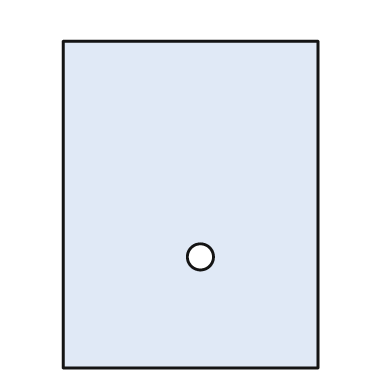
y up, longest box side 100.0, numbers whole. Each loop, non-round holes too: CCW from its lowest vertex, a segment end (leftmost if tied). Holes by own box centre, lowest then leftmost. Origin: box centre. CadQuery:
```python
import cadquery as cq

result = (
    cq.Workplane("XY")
    .moveTo(-39.0, -50.0)
    .lineTo(39.0, -50.0)
    .lineTo(39.0, 50.0)
    .lineTo(-39.0, 50.0)
    .close()
    .moveTo(3.0, -16.0)
    .circle(4.0)
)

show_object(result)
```